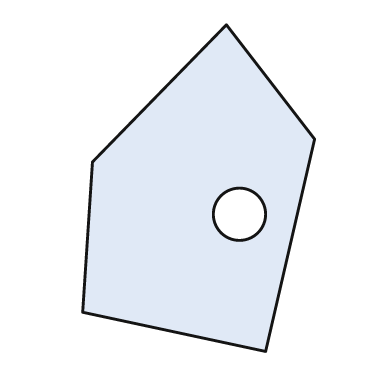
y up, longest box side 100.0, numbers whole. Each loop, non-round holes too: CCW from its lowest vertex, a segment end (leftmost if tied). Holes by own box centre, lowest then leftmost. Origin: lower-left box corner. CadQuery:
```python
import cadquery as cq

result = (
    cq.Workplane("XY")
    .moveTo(56.0, 0.0)
    .lineTo(71.0, 65.0)
    .lineTo(44.0, 100.0)
    .lineTo(3.0, 58.0)
    .lineTo(0.0, 12.0)
    .close()
    .moveTo(48.0, 42.0)
    .circle(8.0)
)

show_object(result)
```